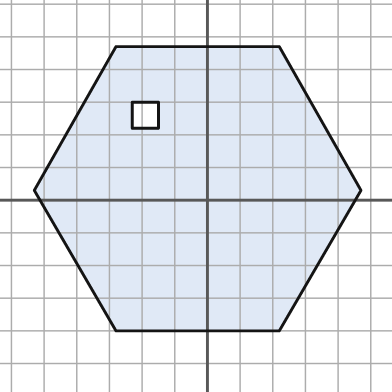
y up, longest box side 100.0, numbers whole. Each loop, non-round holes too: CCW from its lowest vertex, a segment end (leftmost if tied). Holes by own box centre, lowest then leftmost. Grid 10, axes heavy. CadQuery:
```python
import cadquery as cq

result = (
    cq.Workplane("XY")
    .moveTo(-28.0, -40.0)
    .lineTo(22.0, -40.0)
    .lineTo(47.0, 3.0)
    .lineTo(22.0, 47.0)
    .lineTo(-28.0, 47.0)
    .lineTo(-53.0, 3.0)
    .close()
    .moveTo(-23.0, 22.0)
    .lineTo(-15.0, 22.0)
    .lineTo(-15.0, 30.0)
    .lineTo(-23.0, 30.0)
    .close()
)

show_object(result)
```